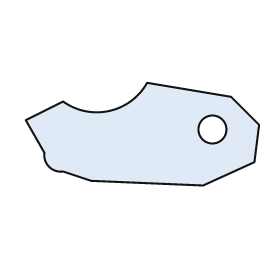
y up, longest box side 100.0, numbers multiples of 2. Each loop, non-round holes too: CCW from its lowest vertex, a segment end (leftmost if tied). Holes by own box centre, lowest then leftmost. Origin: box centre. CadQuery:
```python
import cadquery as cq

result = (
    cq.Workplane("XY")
    .moveTo(26.0, -22.0)
    .lineTo(48.0, -12.0)
    .lineTo(50.0, 4.0)
    .lineTo(38.0, 16.0)
    .lineTo(2.0, 22.0)
    .threePointArc((-14.0, 10.0), (-34.0, 14.0))
    .lineTo(-50.0, 6.0)
    .lineTo(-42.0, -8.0)
    .threePointArc((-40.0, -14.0), (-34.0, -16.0))
    .lineTo(-22.0, -20.0)
    .close()
    .moveTo(30.0, 2.0)
    .circle(6.0)
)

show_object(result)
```